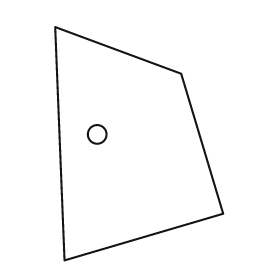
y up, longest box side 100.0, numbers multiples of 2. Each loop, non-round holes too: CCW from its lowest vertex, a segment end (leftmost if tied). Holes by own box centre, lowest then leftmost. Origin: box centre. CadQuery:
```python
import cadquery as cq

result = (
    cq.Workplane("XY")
    .moveTo(-32.0, -50.0)
    .lineTo(36.0, -30.0)
    .lineTo(18.0, 30.0)
    .lineTo(-36.0, 50.0)
    .close()
    .moveTo(-18.0, 4.0)
    .circle(4.0)
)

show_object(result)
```